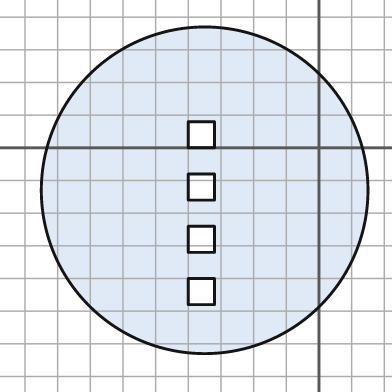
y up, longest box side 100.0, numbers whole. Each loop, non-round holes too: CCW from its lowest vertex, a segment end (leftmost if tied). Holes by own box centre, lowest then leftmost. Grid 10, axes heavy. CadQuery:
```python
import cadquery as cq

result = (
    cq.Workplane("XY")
    .moveTo(-35.0, -13.0)
    .circle(50.0)
    .moveTo(-40.0, -48.0)
    .lineTo(-32.0, -48.0)
    .lineTo(-32.0, -40.0)
    .lineTo(-40.0, -40.0)
    .close()
    .moveTo(-40.0, -32.0)
    .lineTo(-32.0, -32.0)
    .lineTo(-32.0, -24.0)
    .lineTo(-40.0, -24.0)
    .close()
    .moveTo(-40.0, -16.0)
    .lineTo(-32.0, -16.0)
    .lineTo(-32.0, -8.0)
    .lineTo(-40.0, -8.0)
    .close()
    .moveTo(-40.0, 0.0)
    .lineTo(-32.0, 0.0)
    .lineTo(-32.0, 8.0)
    .lineTo(-40.0, 8.0)
    .close()
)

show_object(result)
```